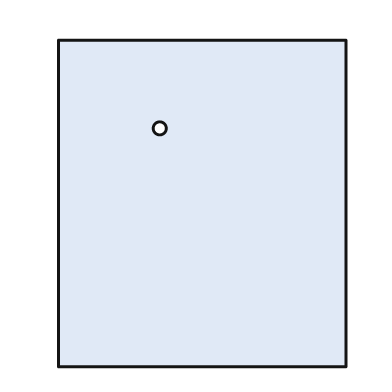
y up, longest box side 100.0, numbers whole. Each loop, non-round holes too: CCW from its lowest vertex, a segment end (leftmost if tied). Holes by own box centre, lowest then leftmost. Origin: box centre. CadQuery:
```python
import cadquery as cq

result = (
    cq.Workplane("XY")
    .moveTo(-44.0, -50.0)
    .lineTo(44.0, -50.0)
    .lineTo(44.0, 50.0)
    .lineTo(-44.0, 50.0)
    .close()
    .moveTo(-13.0, 23.0)
    .circle(2.0)
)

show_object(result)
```